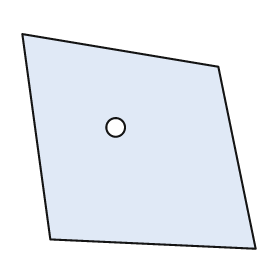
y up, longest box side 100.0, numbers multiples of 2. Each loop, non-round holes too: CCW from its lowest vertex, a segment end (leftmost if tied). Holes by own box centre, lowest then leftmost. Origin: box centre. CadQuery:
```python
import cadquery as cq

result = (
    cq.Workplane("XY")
    .moveTo(50.0, -46.0)
    .lineTo(34.0, 32.0)
    .lineTo(-50.0, 46.0)
    .lineTo(-38.0, -42.0)
    .close()
    .moveTo(-10.0, 6.0)
    .circle(4.0)
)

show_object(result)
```